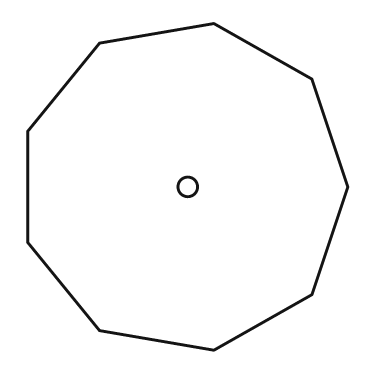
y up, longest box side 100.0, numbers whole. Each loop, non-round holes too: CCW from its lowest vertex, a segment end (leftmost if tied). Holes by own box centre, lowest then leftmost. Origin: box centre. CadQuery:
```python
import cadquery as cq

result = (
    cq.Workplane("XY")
    .moveTo(8.0, -50.0)
    .lineTo(38.0, -33.0)
    .lineTo(49.0, 0.0)
    .lineTo(38.0, 33.0)
    .lineTo(8.0, 50.0)
    .lineTo(-27.0, 44.0)
    .lineTo(-49.0, 17.0)
    .lineTo(-49.0, -17.0)
    .lineTo(-27.0, -44.0)
    .close()
    .moveTo(0.0, 0.0)
    .circle(3.0)
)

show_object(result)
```